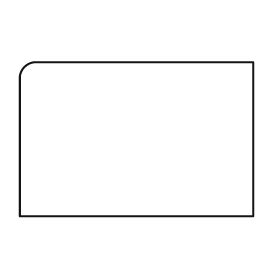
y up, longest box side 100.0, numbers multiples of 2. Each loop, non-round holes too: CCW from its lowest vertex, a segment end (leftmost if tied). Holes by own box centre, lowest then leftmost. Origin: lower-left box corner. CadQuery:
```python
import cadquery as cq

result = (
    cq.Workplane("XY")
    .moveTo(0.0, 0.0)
    .lineTo(100.0, 0.0)
    .lineTo(100.0, 66.0)
    .lineTo(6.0, 66.0)
    .threePointArc((2.0, 64.0), (0.0, 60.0))
    .close()
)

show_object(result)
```